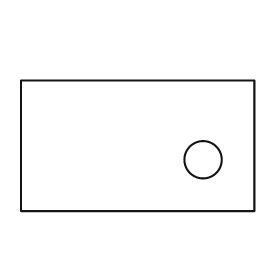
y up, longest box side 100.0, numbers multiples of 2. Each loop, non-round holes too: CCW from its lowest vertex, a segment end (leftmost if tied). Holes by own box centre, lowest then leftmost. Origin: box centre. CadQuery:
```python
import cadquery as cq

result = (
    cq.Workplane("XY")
    .moveTo(-50.0, -28.0)
    .lineTo(50.0, -28.0)
    .lineTo(50.0, 28.0)
    .lineTo(-50.0, 28.0)
    .close()
    .moveTo(28.0, -6.0)
    .circle(8.0)
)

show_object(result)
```